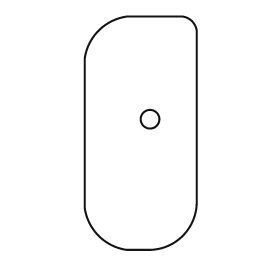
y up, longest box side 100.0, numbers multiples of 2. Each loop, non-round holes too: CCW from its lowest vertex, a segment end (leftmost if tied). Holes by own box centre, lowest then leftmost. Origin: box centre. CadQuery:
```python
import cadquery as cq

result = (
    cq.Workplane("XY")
    .moveTo(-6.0, -50.0)
    .lineTo(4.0, -50.0)
    .threePointArc((18.0, -44.0), (24.0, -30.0))
    .lineTo(24.0, 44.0)
    .threePointArc((22.0, 48.0), (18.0, 50.0))
    .lineTo(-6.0, 50.0)
    .threePointArc((-18.0, 44.0), (-24.0, 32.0))
    .lineTo(-24.0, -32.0)
    .threePointArc((-18.0, -44.0), (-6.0, -50.0))
    .close()
    .moveTo(4.0, 6.0)
    .circle(4.0)
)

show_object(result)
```